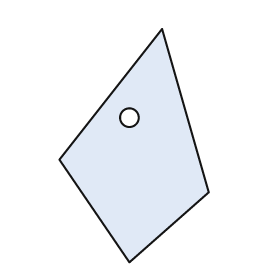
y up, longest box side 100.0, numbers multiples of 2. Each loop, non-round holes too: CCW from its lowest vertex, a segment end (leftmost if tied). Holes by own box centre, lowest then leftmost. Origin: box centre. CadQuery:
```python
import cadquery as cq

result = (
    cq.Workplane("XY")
    .moveTo(-2.0, -50.0)
    .lineTo(32.0, -20.0)
    .lineTo(12.0, 50.0)
    .lineTo(-32.0, -6.0)
    .close()
    .moveTo(-2.0, 12.0)
    .circle(4.0)
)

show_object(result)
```